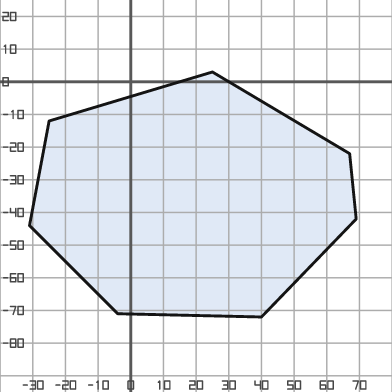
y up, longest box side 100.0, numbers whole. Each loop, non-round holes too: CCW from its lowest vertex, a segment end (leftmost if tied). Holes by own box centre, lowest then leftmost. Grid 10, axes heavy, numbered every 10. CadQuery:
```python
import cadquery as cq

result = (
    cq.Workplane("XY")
    .moveTo(40.0, -72.0)
    .lineTo(69.0, -42.0)
    .lineTo(67.0, -22.0)
    .lineTo(25.0, 3.0)
    .lineTo(-25.0, -12.0)
    .lineTo(-31.0, -44.0)
    .lineTo(-4.0, -71.0)
    .close()
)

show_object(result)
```